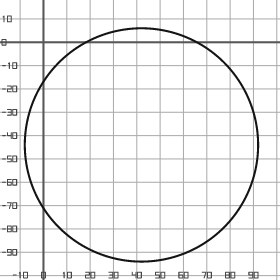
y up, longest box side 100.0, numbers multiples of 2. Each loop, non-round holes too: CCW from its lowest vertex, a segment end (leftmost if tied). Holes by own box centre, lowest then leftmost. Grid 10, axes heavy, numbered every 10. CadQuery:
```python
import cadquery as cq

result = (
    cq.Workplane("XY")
    .moveTo(42.0, -44.0)
    .circle(50.0)
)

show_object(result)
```